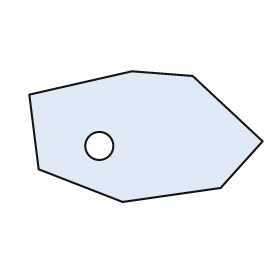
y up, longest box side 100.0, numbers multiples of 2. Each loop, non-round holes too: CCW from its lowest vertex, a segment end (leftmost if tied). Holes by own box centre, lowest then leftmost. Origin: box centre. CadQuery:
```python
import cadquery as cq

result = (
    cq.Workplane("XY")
    .moveTo(-10.0, -28.0)
    .lineTo(32.0, -22.0)
    .lineTo(50.0, -2.0)
    .lineTo(20.0, 26.0)
    .lineTo(-6.0, 28.0)
    .lineTo(-50.0, 18.0)
    .lineTo(-46.0, -14.0)
    .close()
    .moveTo(-20.0, -4.0)
    .circle(6.0)
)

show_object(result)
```